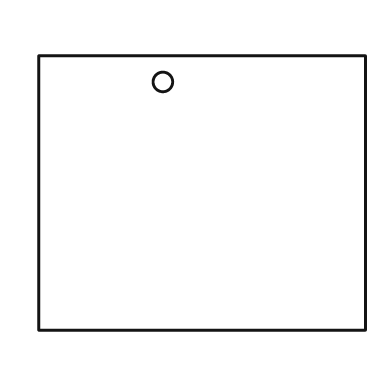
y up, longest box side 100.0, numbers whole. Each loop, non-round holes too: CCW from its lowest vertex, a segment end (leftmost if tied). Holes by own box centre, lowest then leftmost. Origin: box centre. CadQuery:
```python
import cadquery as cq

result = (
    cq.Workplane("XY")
    .moveTo(-50.0, -42.0)
    .lineTo(50.0, -42.0)
    .lineTo(50.0, 42.0)
    .lineTo(-50.0, 42.0)
    .close()
    .moveTo(-12.0, 34.0)
    .circle(3.0)
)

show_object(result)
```